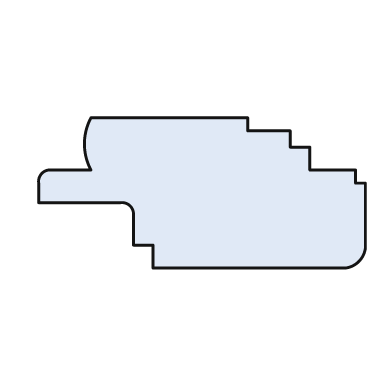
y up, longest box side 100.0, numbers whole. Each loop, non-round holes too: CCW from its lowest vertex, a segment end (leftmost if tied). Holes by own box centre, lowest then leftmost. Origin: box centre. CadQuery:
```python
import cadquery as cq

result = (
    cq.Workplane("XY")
    .moveTo(-15.0, -23.0)
    .lineTo(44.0, -23.0)
    .threePointArc((48.0, -21.0), (50.0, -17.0))
    .lineTo(50.0, 3.0)
    .lineTo(47.0, 3.0)
    .lineTo(47.0, 7.0)
    .lineTo(33.0, 7.0)
    .lineTo(33.0, 14.0)
    .lineTo(27.0, 14.0)
    .lineTo(27.0, 19.0)
    .lineTo(14.0, 19.0)
    .lineTo(14.0, 23.0)
    .lineTo(-34.0, 23.0)
    .threePointArc((-36.0, 15.0), (-34.0, 7.0))
    .lineTo(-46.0, 7.0)
    .threePointArc((-49.0, 6.0), (-50.0, 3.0))
    .lineTo(-50.0, -3.0)
    .lineTo(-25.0, -3.0)
    .threePointArc((-22.0, -4.0), (-21.0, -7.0))
    .lineTo(-21.0, -16.0)
    .lineTo(-15.0, -16.0)
    .close()
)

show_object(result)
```